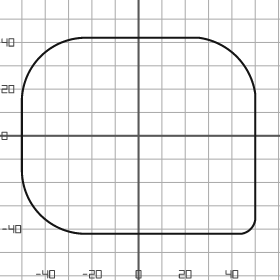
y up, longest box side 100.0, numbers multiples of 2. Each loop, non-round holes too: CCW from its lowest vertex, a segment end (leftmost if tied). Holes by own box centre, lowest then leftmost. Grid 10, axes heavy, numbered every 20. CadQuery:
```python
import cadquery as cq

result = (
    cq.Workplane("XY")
    .moveTo(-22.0, -42.0)
    .lineTo(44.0, -42.0)
    .threePointArc((48.0, -40.0), (50.0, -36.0))
    .lineTo(50.0, 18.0)
    .threePointArc((42.0, 34.0), (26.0, 42.0))
    .lineTo(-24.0, 42.0)
    .threePointArc((-42.0, 34.0), (-50.0, 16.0))
    .lineTo(-50.0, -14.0)
    .threePointArc((-42.0, -34.0), (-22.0, -42.0))
    .close()
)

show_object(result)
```